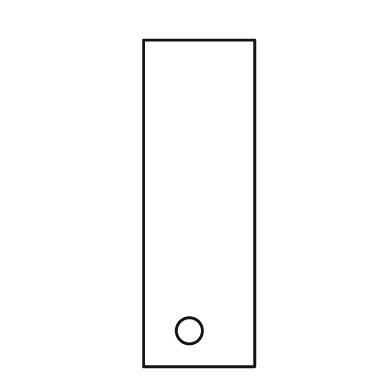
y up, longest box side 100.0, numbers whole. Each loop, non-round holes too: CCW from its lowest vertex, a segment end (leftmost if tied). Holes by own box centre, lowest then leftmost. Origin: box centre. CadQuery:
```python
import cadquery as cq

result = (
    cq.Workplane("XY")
    .moveTo(-17.0, -50.0)
    .lineTo(17.0, -50.0)
    .lineTo(17.0, 50.0)
    .lineTo(-17.0, 50.0)
    .close()
    .moveTo(-3.0, -39.0)
    .circle(4.0)
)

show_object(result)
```